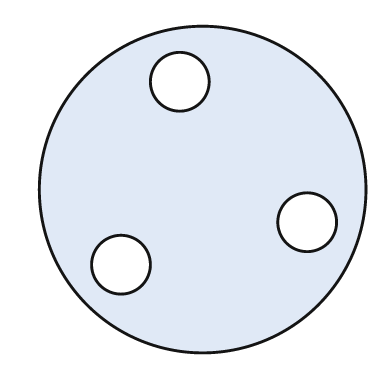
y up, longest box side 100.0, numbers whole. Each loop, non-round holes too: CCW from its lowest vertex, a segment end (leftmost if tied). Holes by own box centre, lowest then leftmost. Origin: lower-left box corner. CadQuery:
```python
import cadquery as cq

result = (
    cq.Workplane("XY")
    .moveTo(50.0, 50.0)
    .circle(50.0)
    .moveTo(25.0, 27.0)
    .circle(9.0)
    .moveTo(82.0, 40.0)
    .circle(9.0)
    .moveTo(43.0, 83.0)
    .circle(9.0)
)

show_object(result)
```